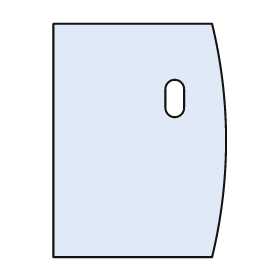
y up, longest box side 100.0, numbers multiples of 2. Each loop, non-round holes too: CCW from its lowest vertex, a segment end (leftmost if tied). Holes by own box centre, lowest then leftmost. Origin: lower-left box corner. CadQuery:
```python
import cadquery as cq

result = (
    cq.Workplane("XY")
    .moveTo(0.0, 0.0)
    .lineTo(68.0, 0.0)
    .threePointArc((74.0, 50.0), (68.0, 100.0))
    .lineTo(0.0, 100.0)
    .close()
    .moveTo(48.0, 64.0)
    .threePointArc((52.0, 60.0), (56.0, 64.0))
    .lineTo(56.0, 72.0)
    .threePointArc((52.0, 76.0), (48.0, 72.0))
    .close()
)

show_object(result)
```